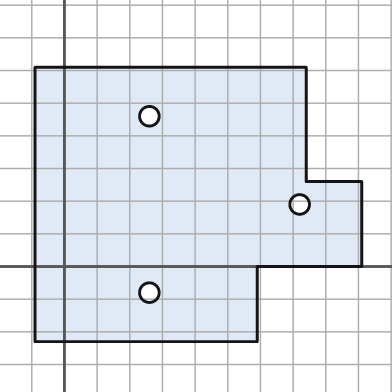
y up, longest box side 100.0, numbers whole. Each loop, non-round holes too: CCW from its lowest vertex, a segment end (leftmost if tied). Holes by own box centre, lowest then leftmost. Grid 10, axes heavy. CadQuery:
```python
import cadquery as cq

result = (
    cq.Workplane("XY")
    .moveTo(-9.0, -23.0)
    .lineTo(59.0, -23.0)
    .lineTo(59.0, 0.0)
    .lineTo(91.0, 0.0)
    .lineTo(91.0, 26.0)
    .lineTo(74.0, 26.0)
    .lineTo(74.0, 61.0)
    .lineTo(-9.0, 61.0)
    .close()
    .moveTo(26.0, -8.0)
    .circle(3.0)
    .moveTo(72.0, 19.0)
    .circle(3.0)
    .moveTo(26.0, 46.0)
    .circle(3.0)
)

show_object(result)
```